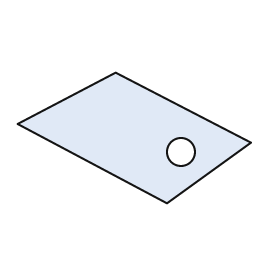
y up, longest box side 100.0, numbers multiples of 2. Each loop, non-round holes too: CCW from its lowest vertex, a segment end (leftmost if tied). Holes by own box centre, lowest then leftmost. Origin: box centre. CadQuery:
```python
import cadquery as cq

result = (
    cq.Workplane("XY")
    .moveTo(14.0, -28.0)
    .lineTo(50.0, -2.0)
    .lineTo(-8.0, 28.0)
    .lineTo(-50.0, 6.0)
    .close()
    .moveTo(20.0, -6.0)
    .circle(6.0)
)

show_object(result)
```